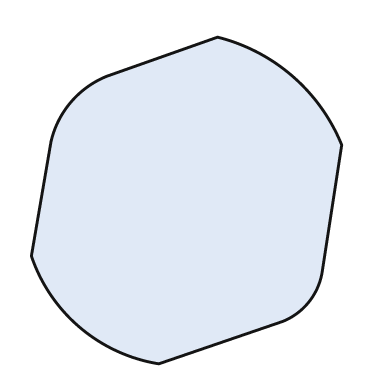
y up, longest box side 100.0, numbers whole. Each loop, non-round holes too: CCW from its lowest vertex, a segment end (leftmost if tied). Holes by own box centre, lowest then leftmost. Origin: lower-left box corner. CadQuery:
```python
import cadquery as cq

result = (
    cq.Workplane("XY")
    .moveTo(39.0, 0.0)
    .lineTo(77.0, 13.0)
    .threePointArc((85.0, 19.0), (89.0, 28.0))
    .lineTo(95.0, 67.0)
    .threePointArc((80.0, 88.0), (57.0, 100.0))
    .lineTo(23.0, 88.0)
    .threePointArc((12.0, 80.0), (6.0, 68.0))
    .lineTo(0.0, 33.0)
    .threePointArc((15.0, 11.0), (39.0, 0.0))
    .close()
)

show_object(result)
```